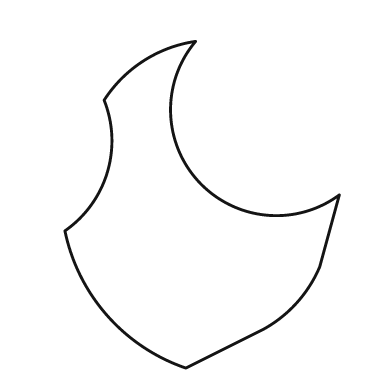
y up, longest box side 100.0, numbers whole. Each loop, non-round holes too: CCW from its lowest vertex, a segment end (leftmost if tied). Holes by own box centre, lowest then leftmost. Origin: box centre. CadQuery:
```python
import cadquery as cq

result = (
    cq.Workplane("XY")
    .moveTo(-5.0, -50.0)
    .lineTo(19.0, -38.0)
    .threePointArc((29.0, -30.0), (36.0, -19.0))
    .lineTo(42.0, 3.0)
    .threePointArc((-1.0, 7.0), (-2.0, 50.0))
    .threePointArc((-18.0, 44.0), (-30.0, 32.0))
    .threePointArc((-29.0, 10.0), (-42.0, -8.0))
    .threePointArc((-29.0, -34.0), (-5.0, -50.0))
    .close()
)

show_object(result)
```